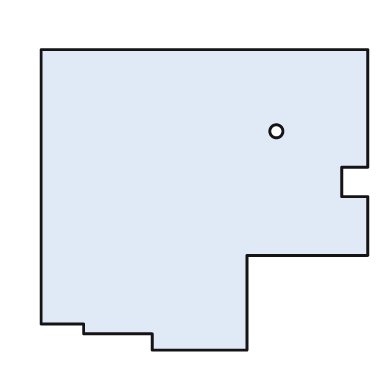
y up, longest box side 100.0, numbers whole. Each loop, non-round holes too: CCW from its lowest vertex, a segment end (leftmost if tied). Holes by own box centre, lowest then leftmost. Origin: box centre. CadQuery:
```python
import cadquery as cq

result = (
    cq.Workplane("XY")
    .moveTo(-16.0, -46.0)
    .lineTo(13.0, -46.0)
    .lineTo(13.0, -17.0)
    .lineTo(50.0, -17.0)
    .lineTo(50.0, 1.0)
    .lineTo(42.0, 1.0)
    .lineTo(42.0, 10.0)
    .lineTo(50.0, 10.0)
    .lineTo(50.0, 46.0)
    .lineTo(-50.0, 46.0)
    .lineTo(-50.0, -38.0)
    .lineTo(-37.0, -38.0)
    .lineTo(-37.0, -41.0)
    .lineTo(-16.0, -41.0)
    .close()
    .moveTo(22.0, 21.0)
    .circle(2.0)
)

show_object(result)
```